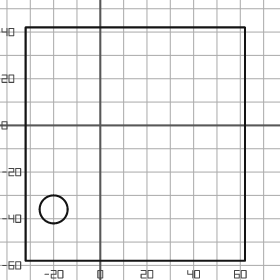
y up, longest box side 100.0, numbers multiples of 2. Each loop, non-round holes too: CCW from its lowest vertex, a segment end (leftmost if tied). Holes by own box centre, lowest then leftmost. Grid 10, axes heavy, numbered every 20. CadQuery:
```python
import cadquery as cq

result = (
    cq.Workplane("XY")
    .moveTo(-32.0, -58.0)
    .lineTo(62.0, -58.0)
    .lineTo(62.0, 42.0)
    .lineTo(-32.0, 42.0)
    .close()
    .moveTo(-20.0, -36.0)
    .circle(6.0)
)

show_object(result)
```